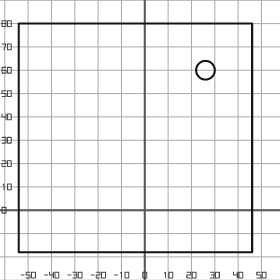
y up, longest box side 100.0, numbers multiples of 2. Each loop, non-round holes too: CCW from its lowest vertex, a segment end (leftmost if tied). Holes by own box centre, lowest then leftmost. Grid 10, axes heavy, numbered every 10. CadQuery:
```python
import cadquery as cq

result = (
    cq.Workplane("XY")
    .moveTo(-54.0, -18.0)
    .lineTo(46.0, -18.0)
    .lineTo(46.0, 80.0)
    .lineTo(-54.0, 80.0)
    .close()
    .moveTo(26.0, 60.0)
    .circle(4.0)
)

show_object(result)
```